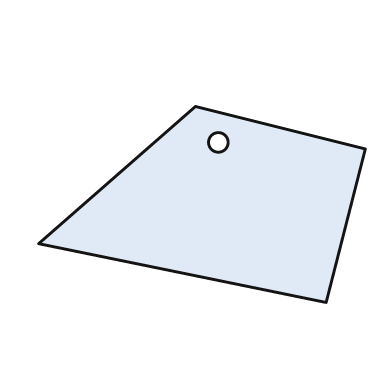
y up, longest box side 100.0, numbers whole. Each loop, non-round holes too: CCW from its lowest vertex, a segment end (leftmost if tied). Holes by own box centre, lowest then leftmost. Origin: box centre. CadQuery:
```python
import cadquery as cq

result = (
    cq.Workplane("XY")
    .moveTo(38.0, -30.0)
    .lineTo(50.0, 17.0)
    .lineTo(-2.0, 30.0)
    .lineTo(-50.0, -12.0)
    .close()
    .moveTo(5.0, 19.0)
    .circle(3.0)
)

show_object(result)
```